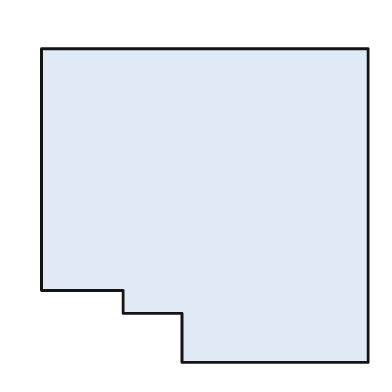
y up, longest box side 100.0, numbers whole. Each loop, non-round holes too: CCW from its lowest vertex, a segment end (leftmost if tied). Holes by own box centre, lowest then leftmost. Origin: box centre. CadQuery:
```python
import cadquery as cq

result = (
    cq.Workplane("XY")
    .moveTo(-7.0, -48.0)
    .lineTo(50.0, -48.0)
    .lineTo(50.0, 48.0)
    .lineTo(-50.0, 48.0)
    .lineTo(-50.0, -26.0)
    .lineTo(-25.0, -26.0)
    .lineTo(-25.0, -33.0)
    .lineTo(-7.0, -33.0)
    .close()
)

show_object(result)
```